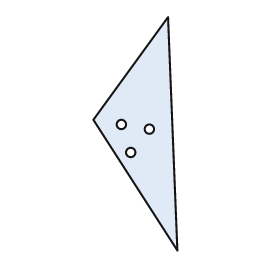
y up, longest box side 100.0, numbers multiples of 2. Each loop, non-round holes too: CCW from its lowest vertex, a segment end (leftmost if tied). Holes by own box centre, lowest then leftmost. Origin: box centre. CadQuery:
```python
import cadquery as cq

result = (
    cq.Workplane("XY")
    .moveTo(18.0, -50.0)
    .lineTo(14.0, 50.0)
    .lineTo(-18.0, 6.0)
    .close()
    .moveTo(-2.0, -8.0)
    .circle(2.0)
    .moveTo(6.0, 2.0)
    .circle(2.0)
    .moveTo(-6.0, 4.0)
    .circle(2.0)
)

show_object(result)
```